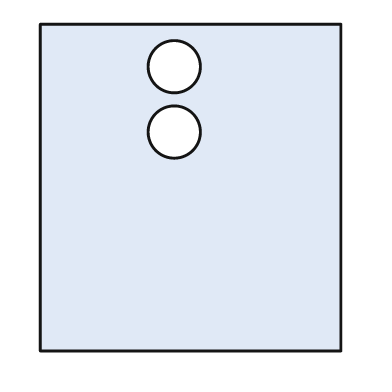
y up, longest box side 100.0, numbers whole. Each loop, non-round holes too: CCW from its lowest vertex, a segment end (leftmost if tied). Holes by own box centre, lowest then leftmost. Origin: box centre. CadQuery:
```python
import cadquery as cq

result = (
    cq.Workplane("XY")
    .moveTo(-46.0, -50.0)
    .lineTo(46.0, -50.0)
    .lineTo(46.0, 50.0)
    .lineTo(-46.0, 50.0)
    .close()
    .moveTo(-5.0, 17.0)
    .circle(8.0)
    .moveTo(-5.0, 37.0)
    .circle(8.0)
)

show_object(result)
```